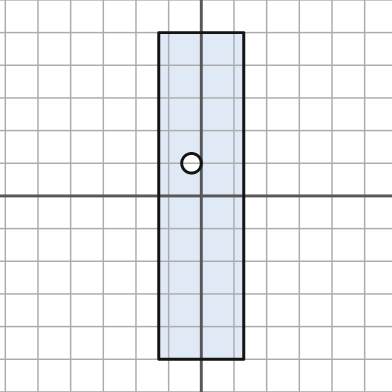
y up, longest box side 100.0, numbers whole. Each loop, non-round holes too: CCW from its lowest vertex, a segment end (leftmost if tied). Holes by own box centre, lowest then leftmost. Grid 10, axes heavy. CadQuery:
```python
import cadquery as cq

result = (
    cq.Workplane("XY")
    .moveTo(-13.0, -50.0)
    .lineTo(13.0, -50.0)
    .lineTo(13.0, 50.0)
    .lineTo(-13.0, 50.0)
    .close()
    .moveTo(-3.0, 10.0)
    .circle(3.0)
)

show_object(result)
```